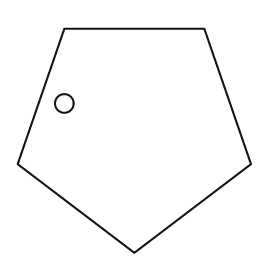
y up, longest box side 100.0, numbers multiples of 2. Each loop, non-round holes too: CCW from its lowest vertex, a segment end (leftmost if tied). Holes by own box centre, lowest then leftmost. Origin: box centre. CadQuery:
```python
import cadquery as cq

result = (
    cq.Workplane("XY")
    .moveTo(0.0, -48.0)
    .lineTo(50.0, -10.0)
    .lineTo(30.0, 48.0)
    .lineTo(-30.0, 48.0)
    .lineTo(-50.0, -10.0)
    .close()
    .moveTo(-30.0, 16.0)
    .circle(4.0)
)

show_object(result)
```